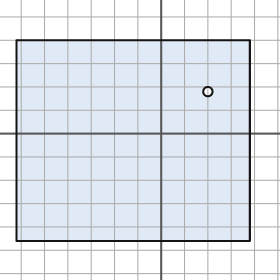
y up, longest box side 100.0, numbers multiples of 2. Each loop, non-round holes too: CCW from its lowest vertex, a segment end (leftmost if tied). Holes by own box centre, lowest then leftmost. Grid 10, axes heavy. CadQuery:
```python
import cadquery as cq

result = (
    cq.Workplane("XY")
    .moveTo(-62.0, -46.0)
    .lineTo(38.0, -46.0)
    .lineTo(38.0, 40.0)
    .lineTo(-62.0, 40.0)
    .close()
    .moveTo(20.0, 18.0)
    .circle(2.0)
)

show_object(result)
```